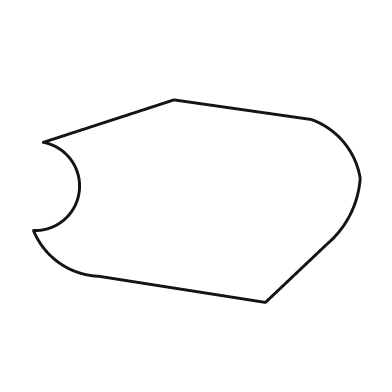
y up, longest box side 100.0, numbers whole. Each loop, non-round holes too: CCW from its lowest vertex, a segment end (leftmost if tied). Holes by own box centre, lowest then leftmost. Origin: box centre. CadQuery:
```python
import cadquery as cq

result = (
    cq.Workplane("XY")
    .moveTo(21.0, -31.0)
    .lineTo(40.0, -13.0)
    .threePointArc((47.0, -4.0), (50.0, 7.0))
    .threePointArc((45.0, 18.0), (35.0, 25.0))
    .lineTo(-7.0, 31.0)
    .lineTo(-47.0, 18.0)
    .threePointArc((-36.0, 3.0), (-50.0, -9.0))
    .threePointArc((-42.0, -19.0), (-30.0, -23.0))
    .close()
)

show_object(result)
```